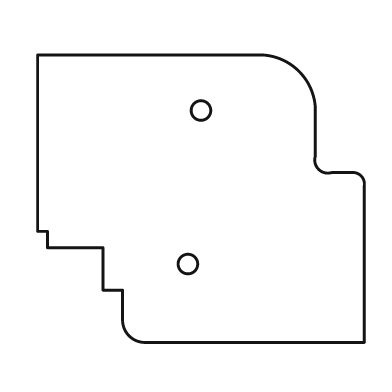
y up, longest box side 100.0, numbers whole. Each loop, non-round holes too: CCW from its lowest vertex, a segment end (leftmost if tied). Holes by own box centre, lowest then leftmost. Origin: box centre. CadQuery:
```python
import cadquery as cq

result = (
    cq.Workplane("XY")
    .moveTo(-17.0, -44.0)
    .lineTo(50.0, -44.0)
    .lineTo(50.0, 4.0)
    .threePointArc((49.0, 7.0), (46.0, 8.0))
    .lineTo(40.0, 8.0)
    .threePointArc((36.0, 9.0), (35.0, 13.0))
    .lineTo(35.0, 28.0)
    .threePointArc((30.0, 39.0), (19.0, 44.0))
    .lineTo(-50.0, 44.0)
    .lineTo(-50.0, -10.0)
    .lineTo(-47.0, -10.0)
    .lineTo(-47.0, -15.0)
    .lineTo(-30.0, -15.0)
    .lineTo(-30.0, -28.0)
    .lineTo(-24.0, -28.0)
    .lineTo(-24.0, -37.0)
    .threePointArc((-22.0, -42.0), (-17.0, -44.0))
    .close()
    .moveTo(-4.0, -20.0)
    .circle(3.0)
    .moveTo(0.0, 27.0)
    .circle(3.0)
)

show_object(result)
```